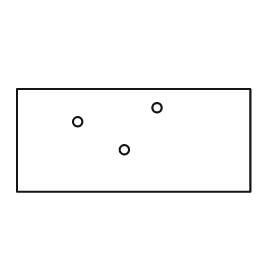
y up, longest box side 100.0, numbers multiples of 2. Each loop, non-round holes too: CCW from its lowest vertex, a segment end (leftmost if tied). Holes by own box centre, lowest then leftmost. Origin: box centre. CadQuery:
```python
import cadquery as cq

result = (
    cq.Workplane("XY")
    .moveTo(-50.0, -22.0)
    .lineTo(50.0, -22.0)
    .lineTo(50.0, 22.0)
    .lineTo(-50.0, 22.0)
    .close()
    .moveTo(-4.0, -4.0)
    .circle(2.0)
    .moveTo(-24.0, 8.0)
    .circle(2.0)
    .moveTo(10.0, 14.0)
    .circle(2.0)
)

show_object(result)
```